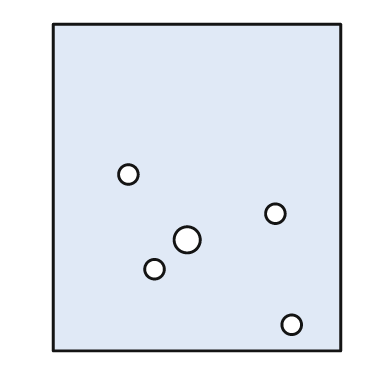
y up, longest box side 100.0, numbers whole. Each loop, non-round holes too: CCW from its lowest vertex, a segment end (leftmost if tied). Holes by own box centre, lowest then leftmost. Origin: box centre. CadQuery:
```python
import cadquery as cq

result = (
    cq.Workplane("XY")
    .moveTo(-44.0, -50.0)
    .lineTo(44.0, -50.0)
    .lineTo(44.0, 50.0)
    .lineTo(-44.0, 50.0)
    .close()
    .moveTo(29.0, -42.0)
    .circle(3.0)
    .moveTo(-13.0, -25.0)
    .circle(3.0)
    .moveTo(-3.0, -16.0)
    .circle(4.0)
    .moveTo(24.0, -8.0)
    .circle(3.0)
    .moveTo(-21.0, 4.0)
    .circle(3.0)
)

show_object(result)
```